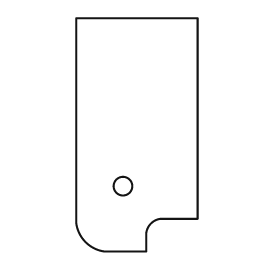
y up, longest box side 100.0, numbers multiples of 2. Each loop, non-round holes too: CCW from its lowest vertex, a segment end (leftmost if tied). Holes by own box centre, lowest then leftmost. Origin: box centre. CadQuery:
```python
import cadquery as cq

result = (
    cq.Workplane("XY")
    .moveTo(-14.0, -50.0)
    .lineTo(4.0, -50.0)
    .lineTo(4.0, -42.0)
    .threePointArc((6.0, -38.0), (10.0, -36.0))
    .lineTo(26.0, -36.0)
    .lineTo(26.0, 50.0)
    .lineTo(-26.0, 50.0)
    .lineTo(-26.0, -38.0)
    .threePointArc((-22.0, -46.0), (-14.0, -50.0))
    .close()
    .moveTo(-6.0, -22.0)
    .circle(4.0)
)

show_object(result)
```